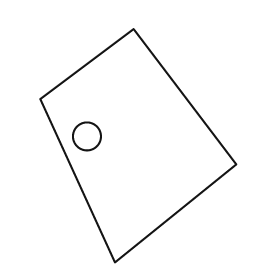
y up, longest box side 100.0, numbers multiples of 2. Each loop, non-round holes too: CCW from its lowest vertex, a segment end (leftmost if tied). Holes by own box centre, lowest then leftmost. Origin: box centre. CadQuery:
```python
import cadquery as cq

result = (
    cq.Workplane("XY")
    .moveTo(-10.0, -50.0)
    .lineTo(42.0, -8.0)
    .lineTo(-2.0, 50.0)
    .lineTo(-42.0, 20.0)
    .close()
    .moveTo(-22.0, 4.0)
    .circle(6.0)
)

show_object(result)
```